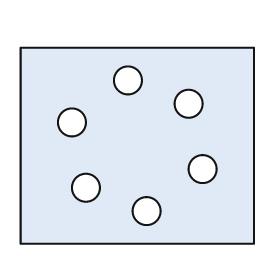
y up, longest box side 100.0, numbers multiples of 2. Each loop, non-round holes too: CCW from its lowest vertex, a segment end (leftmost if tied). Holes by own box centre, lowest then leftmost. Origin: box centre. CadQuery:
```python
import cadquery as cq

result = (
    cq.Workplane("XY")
    .moveTo(-50.0, -42.0)
    .lineTo(50.0, -42.0)
    .lineTo(50.0, 42.0)
    .lineTo(-50.0, 42.0)
    .close()
    .moveTo(4.0, -28.0)
    .circle(6.0)
    .moveTo(-22.0, -18.0)
    .circle(6.0)
    .moveTo(28.0, -10.0)
    .circle(6.0)
    .moveTo(-28.0, 10.0)
    .circle(6.0)
    .moveTo(22.0, 18.0)
    .circle(6.0)
    .moveTo(-4.0, 28.0)
    .circle(6.0)
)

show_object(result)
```